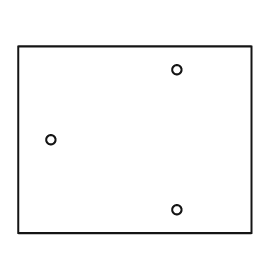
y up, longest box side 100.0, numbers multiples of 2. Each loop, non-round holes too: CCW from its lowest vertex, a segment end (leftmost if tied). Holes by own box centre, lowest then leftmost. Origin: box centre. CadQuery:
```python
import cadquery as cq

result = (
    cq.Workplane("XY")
    .moveTo(-50.0, -40.0)
    .lineTo(50.0, -40.0)
    .lineTo(50.0, 40.0)
    .lineTo(-50.0, 40.0)
    .close()
    .moveTo(18.0, -30.0)
    .circle(2.0)
    .moveTo(-36.0, 0.0)
    .circle(2.0)
    .moveTo(18.0, 30.0)
    .circle(2.0)
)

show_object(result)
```